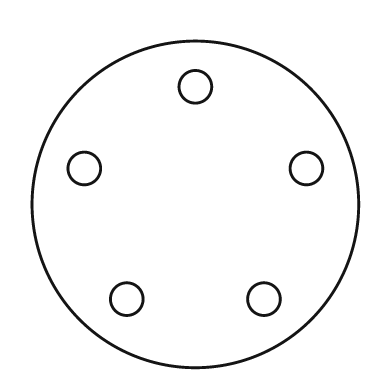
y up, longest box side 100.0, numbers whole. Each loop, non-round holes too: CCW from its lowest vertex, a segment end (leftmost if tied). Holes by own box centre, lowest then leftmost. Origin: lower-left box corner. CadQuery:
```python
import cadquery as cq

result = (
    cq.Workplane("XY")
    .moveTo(50.0, 50.0)
    .circle(50.0)
    .moveTo(29.0, 21.0)
    .circle(5.0)
    .moveTo(71.0, 21.0)
    .circle(5.0)
    .moveTo(16.0, 61.0)
    .circle(5.0)
    .moveTo(84.0, 61.0)
    .circle(5.0)
    .moveTo(50.0, 86.0)
    .circle(5.0)
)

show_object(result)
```